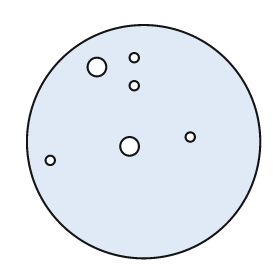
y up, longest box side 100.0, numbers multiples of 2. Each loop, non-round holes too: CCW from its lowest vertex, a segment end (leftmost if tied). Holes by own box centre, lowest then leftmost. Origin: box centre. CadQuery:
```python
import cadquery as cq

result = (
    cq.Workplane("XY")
    .moveTo(0.0, 0.0)
    .circle(50.0)
    .moveTo(-40.0, -8.0)
    .circle(2.0)
    .moveTo(-6.0, -2.0)
    .circle(4.0)
    .moveTo(20.0, 2.0)
    .circle(2.0)
    .moveTo(-4.0, 24.0)
    .circle(2.0)
    .moveTo(-20.0, 32.0)
    .circle(4.0)
    .moveTo(-4.0, 36.0)
    .circle(2.0)
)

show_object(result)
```